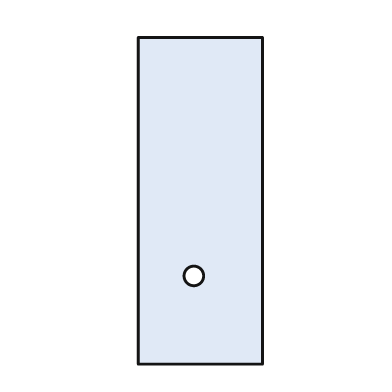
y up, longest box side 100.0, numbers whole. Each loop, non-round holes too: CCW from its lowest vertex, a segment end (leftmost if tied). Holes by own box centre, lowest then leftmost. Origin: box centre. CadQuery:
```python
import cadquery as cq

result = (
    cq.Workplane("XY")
    .moveTo(-19.0, -50.0)
    .lineTo(19.0, -50.0)
    .lineTo(19.0, 50.0)
    .lineTo(-19.0, 50.0)
    .close()
    .moveTo(-2.0, -23.0)
    .circle(3.0)
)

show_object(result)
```